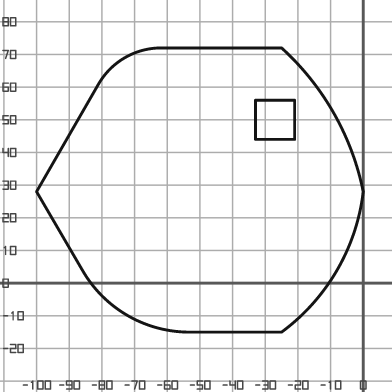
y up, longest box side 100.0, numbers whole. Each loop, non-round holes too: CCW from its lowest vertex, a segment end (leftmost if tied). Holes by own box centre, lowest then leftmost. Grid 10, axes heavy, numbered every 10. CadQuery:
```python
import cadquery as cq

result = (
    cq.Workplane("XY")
    .moveTo(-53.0, -15.0)
    .lineTo(-25.0, -15.0)
    .threePointArc((-8.0, 4.0), (0.0, 28.0))
    .threePointArc((-9.0, 52.0), (-25.0, 72.0))
    .lineTo(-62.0, 72.0)
    .threePointArc((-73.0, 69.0), (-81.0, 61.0))
    .lineTo(-100.0, 28.0)
    .lineTo(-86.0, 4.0)
    .threePointArc((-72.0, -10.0), (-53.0, -15.0))
    .close()
    .moveTo(-33.0, 44.0)
    .lineTo(-21.0, 44.0)
    .lineTo(-21.0, 56.0)
    .lineTo(-33.0, 56.0)
    .close()
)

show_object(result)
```